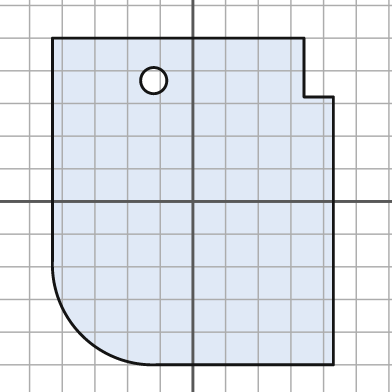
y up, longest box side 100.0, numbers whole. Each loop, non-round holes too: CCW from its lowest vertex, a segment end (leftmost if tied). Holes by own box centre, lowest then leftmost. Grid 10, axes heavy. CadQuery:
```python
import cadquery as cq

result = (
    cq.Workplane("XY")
    .moveTo(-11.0, -50.0)
    .lineTo(43.0, -50.0)
    .lineTo(43.0, 32.0)
    .lineTo(34.0, 32.0)
    .lineTo(34.0, 50.0)
    .lineTo(-43.0, 50.0)
    .lineTo(-43.0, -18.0)
    .threePointArc((-34.0, -41.0), (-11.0, -50.0))
    .close()
    .moveTo(-12.0, 37.0)
    .circle(4.0)
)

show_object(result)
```